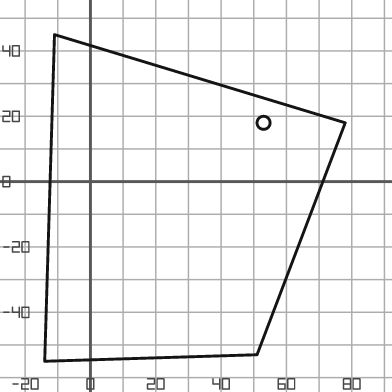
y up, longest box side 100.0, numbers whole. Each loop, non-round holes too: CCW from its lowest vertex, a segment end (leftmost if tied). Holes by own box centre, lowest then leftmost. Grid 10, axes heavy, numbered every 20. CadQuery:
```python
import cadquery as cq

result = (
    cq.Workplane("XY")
    .moveTo(-14.0, -55.0)
    .lineTo(51.0, -53.0)
    .lineTo(78.0, 18.0)
    .lineTo(-11.0, 45.0)
    .close()
    .moveTo(53.0, 18.0)
    .circle(2.0)
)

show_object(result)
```